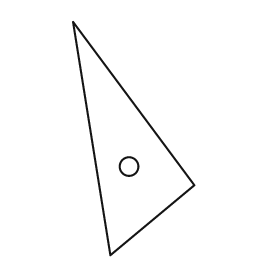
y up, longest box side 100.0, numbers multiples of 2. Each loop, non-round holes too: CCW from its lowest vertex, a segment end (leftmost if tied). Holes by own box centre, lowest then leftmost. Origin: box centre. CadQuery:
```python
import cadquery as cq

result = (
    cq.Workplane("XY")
    .moveTo(-10.0, -50.0)
    .lineTo(26.0, -20.0)
    .lineTo(-26.0, 50.0)
    .close()
    .moveTo(-2.0, -12.0)
    .circle(4.0)
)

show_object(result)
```